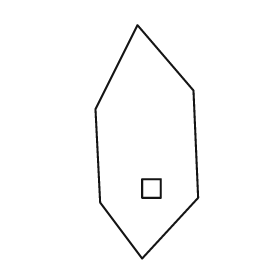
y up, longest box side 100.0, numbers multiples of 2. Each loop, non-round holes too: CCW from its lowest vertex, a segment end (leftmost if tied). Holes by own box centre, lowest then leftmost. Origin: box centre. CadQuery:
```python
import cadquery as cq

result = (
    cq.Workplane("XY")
    .moveTo(-2.0, -50.0)
    .lineTo(22.0, -24.0)
    .lineTo(20.0, 22.0)
    .lineTo(-4.0, 50.0)
    .lineTo(-22.0, 14.0)
    .lineTo(-20.0, -26.0)
    .close()
    .moveTo(-2.0, -24.0)
    .lineTo(6.0, -24.0)
    .lineTo(6.0, -16.0)
    .lineTo(-2.0, -16.0)
    .close()
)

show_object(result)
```